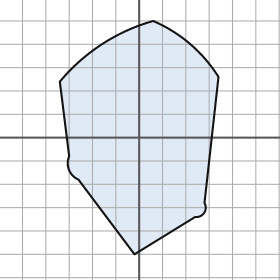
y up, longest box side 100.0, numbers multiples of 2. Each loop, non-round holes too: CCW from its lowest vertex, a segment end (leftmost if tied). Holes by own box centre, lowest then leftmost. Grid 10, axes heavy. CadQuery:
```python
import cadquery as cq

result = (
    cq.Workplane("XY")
    .moveTo(-2.0, -50.0)
    .lineTo(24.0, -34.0)
    .threePointArc((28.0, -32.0), (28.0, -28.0))
    .lineTo(34.0, 26.0)
    .threePointArc((22.0, 40.0), (6.0, 50.0))
    .threePointArc((-16.0, 40.0), (-34.0, 24.0))
    .lineTo(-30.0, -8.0)
    .threePointArc((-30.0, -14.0), (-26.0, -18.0))
    .close()
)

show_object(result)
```